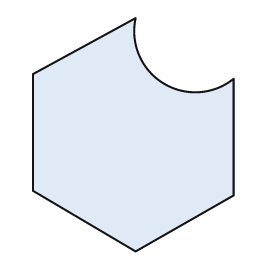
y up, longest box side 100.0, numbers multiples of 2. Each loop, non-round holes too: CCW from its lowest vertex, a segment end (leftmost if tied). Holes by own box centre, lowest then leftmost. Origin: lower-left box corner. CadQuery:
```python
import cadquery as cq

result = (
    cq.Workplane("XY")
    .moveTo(44.0, 0.0)
    .lineTo(86.0, 24.0)
    .lineTo(86.0, 74.0)
    .threePointArc((56.0, 72.0), (44.0, 100.0))
    .lineTo(0.0, 76.0)
    .lineTo(0.0, 26.0)
    .close()
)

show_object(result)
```